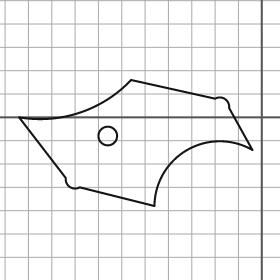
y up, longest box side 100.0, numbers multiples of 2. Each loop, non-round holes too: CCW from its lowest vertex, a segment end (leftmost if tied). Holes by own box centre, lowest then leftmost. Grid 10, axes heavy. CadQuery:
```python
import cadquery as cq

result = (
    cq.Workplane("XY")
    .moveTo(-46.0, -38.0)
    .threePointArc((-32.0, -14.0), (-4.0, -14.0))
    .lineTo(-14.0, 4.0)
    .threePointArc((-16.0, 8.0), (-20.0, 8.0))
    .lineTo(-56.0, 16.0)
    .threePointArc((-78.0, 2.0), (-104.0, 0.0))
    .lineTo(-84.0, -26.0)
    .threePointArc((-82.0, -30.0), (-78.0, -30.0))
    .close()
    .moveTo(-66.0, -8.0)
    .circle(4.0)
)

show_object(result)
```